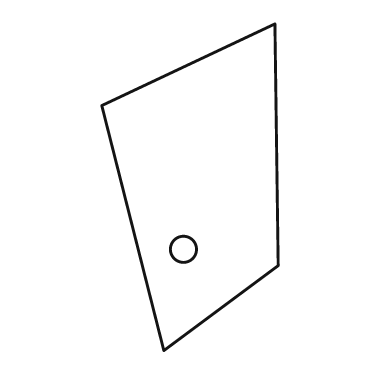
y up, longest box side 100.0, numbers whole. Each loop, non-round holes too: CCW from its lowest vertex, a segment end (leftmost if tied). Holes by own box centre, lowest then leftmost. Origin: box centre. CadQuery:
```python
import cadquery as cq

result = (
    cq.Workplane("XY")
    .moveTo(-8.0, -50.0)
    .lineTo(27.0, -24.0)
    .lineTo(26.0, 50.0)
    .lineTo(-27.0, 25.0)
    .close()
    .moveTo(-2.0, -19.0)
    .circle(4.0)
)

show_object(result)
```